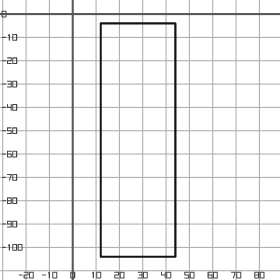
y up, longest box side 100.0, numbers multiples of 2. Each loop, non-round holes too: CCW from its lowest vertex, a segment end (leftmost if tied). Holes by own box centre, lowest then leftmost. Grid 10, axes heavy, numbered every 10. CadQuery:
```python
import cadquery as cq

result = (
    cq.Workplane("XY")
    .moveTo(12.0, -104.0)
    .lineTo(44.0, -104.0)
    .lineTo(44.0, -4.0)
    .lineTo(12.0, -4.0)
    .close()
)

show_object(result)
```